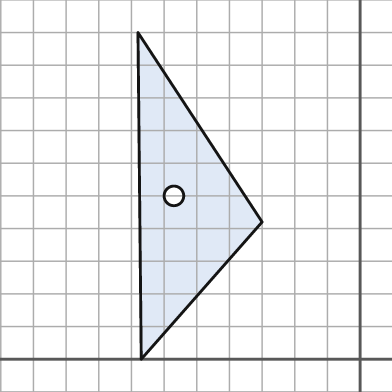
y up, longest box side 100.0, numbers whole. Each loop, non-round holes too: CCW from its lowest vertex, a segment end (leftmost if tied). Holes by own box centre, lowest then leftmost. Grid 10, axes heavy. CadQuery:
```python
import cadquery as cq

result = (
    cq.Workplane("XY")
    .moveTo(-67.0, 0.0)
    .lineTo(-30.0, 42.0)
    .lineTo(-68.0, 100.0)
    .close()
    .moveTo(-57.0, 50.0)
    .circle(3.0)
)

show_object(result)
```